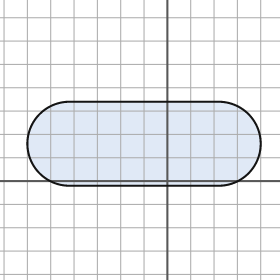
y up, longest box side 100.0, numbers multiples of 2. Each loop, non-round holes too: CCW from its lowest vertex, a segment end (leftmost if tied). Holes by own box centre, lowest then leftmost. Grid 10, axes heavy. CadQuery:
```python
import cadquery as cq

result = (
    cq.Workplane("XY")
    .moveTo(-42.0, -2.0)
    .lineTo(22.0, -2.0)
    .threePointArc((40.0, 16.0), (22.0, 34.0))
    .lineTo(-42.0, 34.0)
    .threePointArc((-60.0, 16.0), (-42.0, -2.0))
    .close()
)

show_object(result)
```